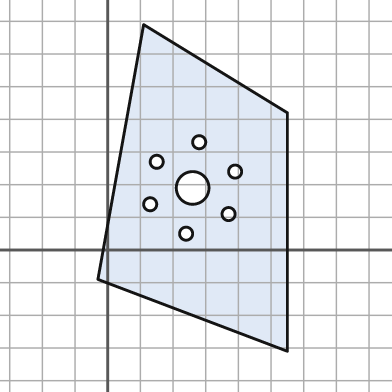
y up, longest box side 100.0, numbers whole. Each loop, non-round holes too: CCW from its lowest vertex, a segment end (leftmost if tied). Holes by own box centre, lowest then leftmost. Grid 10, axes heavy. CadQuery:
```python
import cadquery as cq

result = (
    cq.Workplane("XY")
    .moveTo(55.0, -31.0)
    .lineTo(55.0, 42.0)
    .lineTo(11.0, 69.0)
    .lineTo(-3.0, -9.0)
    .close()
    .moveTo(24.0, 5.0)
    .circle(2.0)
    .moveTo(37.0, 11.0)
    .circle(2.0)
    .moveTo(13.0, 14.0)
    .circle(2.0)
    .moveTo(26.0, 19.0)
    .circle(5.0)
    .moveTo(39.0, 24.0)
    .circle(2.0)
    .moveTo(15.0, 27.0)
    .circle(2.0)
    .moveTo(28.0, 33.0)
    .circle(2.0)
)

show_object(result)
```